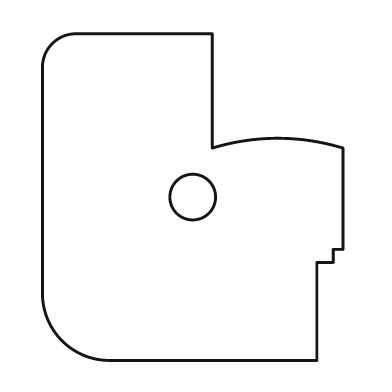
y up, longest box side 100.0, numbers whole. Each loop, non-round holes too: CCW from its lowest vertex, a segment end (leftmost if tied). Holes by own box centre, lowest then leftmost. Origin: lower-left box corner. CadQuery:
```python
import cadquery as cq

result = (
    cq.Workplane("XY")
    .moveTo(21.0, 0.0)
    .lineTo(84.0, 0.0)
    .lineTo(84.0, 30.0)
    .lineTo(89.0, 30.0)
    .lineTo(89.0, 34.0)
    .lineTo(92.0, 34.0)
    .lineTo(92.0, 65.0)
    .threePointArc((72.0, 68.0), (52.0, 65.0))
    .lineTo(52.0, 100.0)
    .lineTo(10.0, 100.0)
    .threePointArc((3.0, 97.0), (0.0, 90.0))
    .lineTo(0.0, 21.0)
    .threePointArc((6.0, 6.0), (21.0, 0.0))
    .close()
    .moveTo(46.0, 50.0)
    .circle(7.0)
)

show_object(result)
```